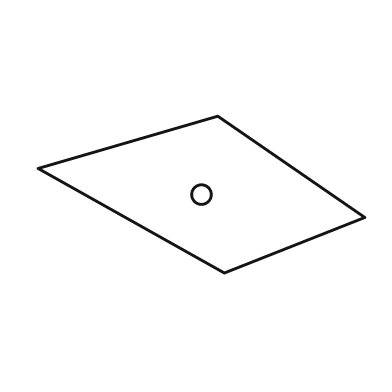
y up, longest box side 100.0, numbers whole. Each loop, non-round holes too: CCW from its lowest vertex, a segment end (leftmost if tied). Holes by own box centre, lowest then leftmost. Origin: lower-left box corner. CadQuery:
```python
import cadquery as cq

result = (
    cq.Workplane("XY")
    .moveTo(57.0, 0.0)
    .lineTo(100.0, 17.0)
    .lineTo(55.0, 48.0)
    .lineTo(0.0, 32.0)
    .close()
    .moveTo(50.0, 24.0)
    .circle(3.0)
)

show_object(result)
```